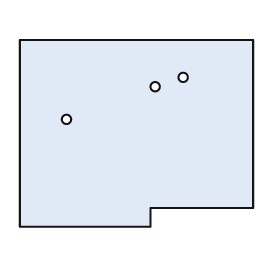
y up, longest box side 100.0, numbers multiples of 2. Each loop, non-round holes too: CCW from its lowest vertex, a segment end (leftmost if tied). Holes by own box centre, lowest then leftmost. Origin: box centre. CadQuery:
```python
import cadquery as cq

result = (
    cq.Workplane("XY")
    .moveTo(-50.0, -40.0)
    .lineTo(6.0, -40.0)
    .lineTo(6.0, -32.0)
    .lineTo(50.0, -32.0)
    .lineTo(50.0, 40.0)
    .lineTo(-50.0, 40.0)
    .close()
    .moveTo(-30.0, 6.0)
    .circle(2.0)
    .moveTo(8.0, 20.0)
    .circle(2.0)
    .moveTo(20.0, 24.0)
    .circle(2.0)
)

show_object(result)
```